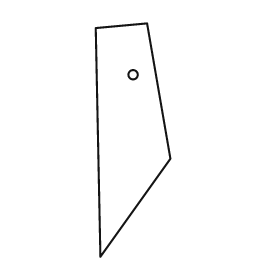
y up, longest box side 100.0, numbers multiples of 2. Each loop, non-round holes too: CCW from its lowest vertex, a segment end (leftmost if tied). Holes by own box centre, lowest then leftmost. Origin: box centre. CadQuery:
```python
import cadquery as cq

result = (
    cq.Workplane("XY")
    .moveTo(-14.0, -50.0)
    .lineTo(16.0, -8.0)
    .lineTo(6.0, 50.0)
    .lineTo(-16.0, 48.0)
    .close()
    .moveTo(0.0, 28.0)
    .circle(2.0)
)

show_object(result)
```